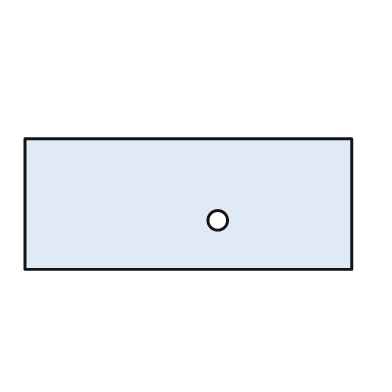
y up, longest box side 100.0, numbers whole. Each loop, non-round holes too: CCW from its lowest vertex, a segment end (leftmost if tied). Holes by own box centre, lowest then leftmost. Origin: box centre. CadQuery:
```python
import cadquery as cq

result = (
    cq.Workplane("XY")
    .moveTo(-50.0, -20.0)
    .lineTo(50.0, -20.0)
    .lineTo(50.0, 20.0)
    .lineTo(-50.0, 20.0)
    .close()
    .moveTo(9.0, -5.0)
    .circle(3.0)
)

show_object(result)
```